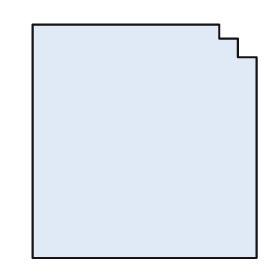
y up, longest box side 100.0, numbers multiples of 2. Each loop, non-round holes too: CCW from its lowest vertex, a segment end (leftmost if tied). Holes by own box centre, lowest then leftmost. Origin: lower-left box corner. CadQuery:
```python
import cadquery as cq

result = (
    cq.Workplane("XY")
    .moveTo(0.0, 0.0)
    .lineTo(96.0, 0.0)
    .lineTo(96.0, 86.0)
    .lineTo(88.0, 86.0)
    .lineTo(88.0, 94.0)
    .lineTo(80.0, 94.0)
    .lineTo(80.0, 100.0)
    .lineTo(0.0, 100.0)
    .close()
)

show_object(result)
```